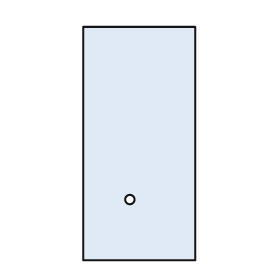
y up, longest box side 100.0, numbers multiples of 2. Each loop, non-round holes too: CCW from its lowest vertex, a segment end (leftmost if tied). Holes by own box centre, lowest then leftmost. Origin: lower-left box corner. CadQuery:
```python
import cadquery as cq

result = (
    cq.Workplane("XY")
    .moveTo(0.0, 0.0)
    .lineTo(48.0, 0.0)
    .lineTo(48.0, 100.0)
    .lineTo(0.0, 100.0)
    .close()
    .moveTo(20.0, 26.0)
    .circle(2.0)
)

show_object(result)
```